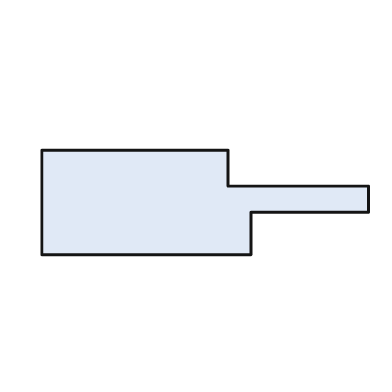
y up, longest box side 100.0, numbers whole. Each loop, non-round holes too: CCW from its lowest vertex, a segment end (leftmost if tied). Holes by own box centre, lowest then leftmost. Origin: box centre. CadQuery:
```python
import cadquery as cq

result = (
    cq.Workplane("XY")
    .moveTo(-50.0, -16.0)
    .lineTo(14.0, -16.0)
    .lineTo(14.0, -3.0)
    .lineTo(50.0, -3.0)
    .lineTo(50.0, 5.0)
    .lineTo(7.0, 5.0)
    .lineTo(7.0, 16.0)
    .lineTo(-50.0, 16.0)
    .close()
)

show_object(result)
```